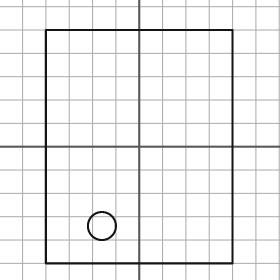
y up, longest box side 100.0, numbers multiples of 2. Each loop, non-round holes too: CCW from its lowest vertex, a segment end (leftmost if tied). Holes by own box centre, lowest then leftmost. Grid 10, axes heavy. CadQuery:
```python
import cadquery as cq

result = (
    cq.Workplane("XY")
    .moveTo(-40.0, -50.0)
    .lineTo(40.0, -50.0)
    .lineTo(40.0, 50.0)
    .lineTo(-40.0, 50.0)
    .close()
    .moveTo(-16.0, -34.0)
    .circle(6.0)
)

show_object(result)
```